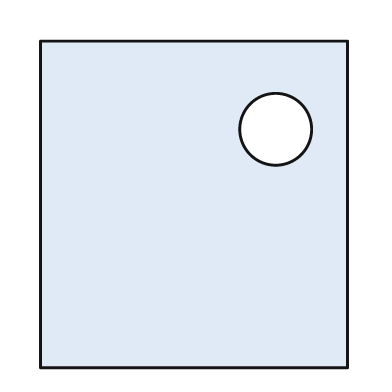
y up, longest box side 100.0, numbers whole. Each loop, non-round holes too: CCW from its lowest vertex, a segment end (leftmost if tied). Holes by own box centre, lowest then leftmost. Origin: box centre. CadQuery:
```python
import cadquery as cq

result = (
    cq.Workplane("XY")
    .moveTo(-47.0, -50.0)
    .lineTo(47.0, -50.0)
    .lineTo(47.0, 50.0)
    .lineTo(-47.0, 50.0)
    .close()
    .moveTo(25.0, 23.0)
    .circle(11.0)
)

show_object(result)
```